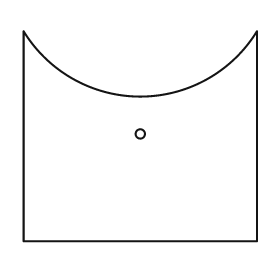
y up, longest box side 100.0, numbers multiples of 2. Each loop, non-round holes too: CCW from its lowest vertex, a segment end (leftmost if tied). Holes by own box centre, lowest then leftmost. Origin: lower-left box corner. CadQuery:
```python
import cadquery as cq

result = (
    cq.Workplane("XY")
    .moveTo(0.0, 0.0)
    .lineTo(100.0, 0.0)
    .lineTo(100.0, 90.0)
    .threePointArc((50.0, 62.0), (0.0, 90.0))
    .close()
    .moveTo(50.0, 46.0)
    .circle(2.0)
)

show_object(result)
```